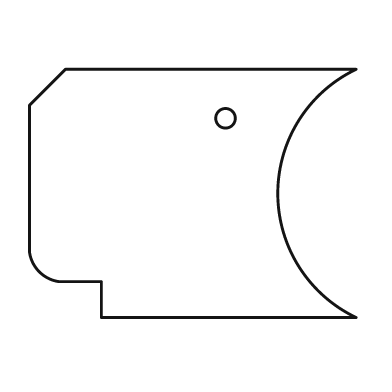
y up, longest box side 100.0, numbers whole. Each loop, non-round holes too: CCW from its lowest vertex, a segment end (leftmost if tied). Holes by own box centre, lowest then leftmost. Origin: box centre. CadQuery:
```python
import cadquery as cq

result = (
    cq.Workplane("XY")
    .moveTo(-28.0, -38.0)
    .lineTo(50.0, -38.0)
    .threePointArc((26.0, 0.0), (50.0, 38.0))
    .lineTo(-39.0, 38.0)
    .lineTo(-50.0, 27.0)
    .lineTo(-50.0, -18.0)
    .threePointArc((-47.0, -24.0), (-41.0, -27.0))
    .lineTo(-28.0, -27.0)
    .close()
    .moveTo(10.0, 23.0)
    .circle(3.0)
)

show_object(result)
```